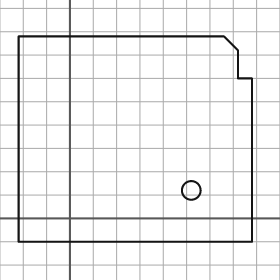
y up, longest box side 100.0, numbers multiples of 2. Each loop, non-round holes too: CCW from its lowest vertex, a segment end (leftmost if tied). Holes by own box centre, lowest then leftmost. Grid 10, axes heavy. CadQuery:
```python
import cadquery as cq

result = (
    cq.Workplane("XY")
    .moveTo(-22.0, -10.0)
    .lineTo(78.0, -10.0)
    .lineTo(78.0, 60.0)
    .lineTo(72.0, 60.0)
    .lineTo(72.0, 72.0)
    .lineTo(66.0, 78.0)
    .lineTo(-22.0, 78.0)
    .close()
    .moveTo(52.0, 12.0)
    .circle(4.0)
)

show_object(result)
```